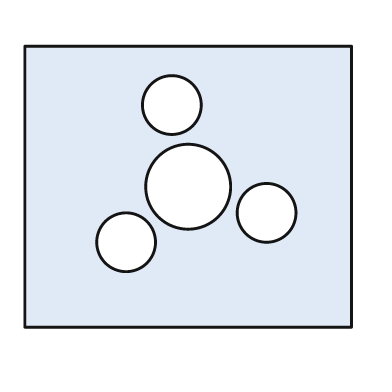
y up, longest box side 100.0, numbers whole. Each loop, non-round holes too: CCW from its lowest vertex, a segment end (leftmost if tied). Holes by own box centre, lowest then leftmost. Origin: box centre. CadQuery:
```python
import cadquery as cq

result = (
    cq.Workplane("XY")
    .moveTo(-50.0, -43.0)
    .lineTo(50.0, -43.0)
    .lineTo(50.0, 43.0)
    .lineTo(-50.0, 43.0)
    .close()
    .moveTo(-19.0, -17.0)
    .circle(9.0)
    .moveTo(24.0, -8.0)
    .circle(9.0)
    .moveTo(0.0, 0.0)
    .circle(13.0)
    .moveTo(-5.0, 25.0)
    .circle(9.0)
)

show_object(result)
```